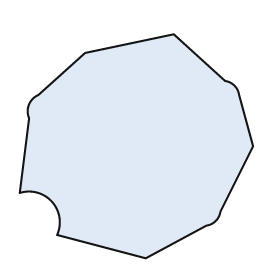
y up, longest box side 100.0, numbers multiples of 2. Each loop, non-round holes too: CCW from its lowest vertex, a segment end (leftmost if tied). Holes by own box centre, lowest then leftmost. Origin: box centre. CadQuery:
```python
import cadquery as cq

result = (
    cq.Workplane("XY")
    .moveTo(4.0, -48.0)
    .lineTo(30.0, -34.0)
    .threePointArc((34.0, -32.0), (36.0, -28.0))
    .lineTo(50.0, 0.0)
    .lineTo(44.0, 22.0)
    .threePointArc((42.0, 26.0), (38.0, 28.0))
    .lineTo(16.0, 48.0)
    .lineTo(-22.0, 40.0)
    .lineTo(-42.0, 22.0)
    .threePointArc((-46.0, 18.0), (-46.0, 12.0))
    .lineTo(-50.0, -20.0)
    .threePointArc((-36.0, -24.0), (-34.0, -38.0))
    .close()
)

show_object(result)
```